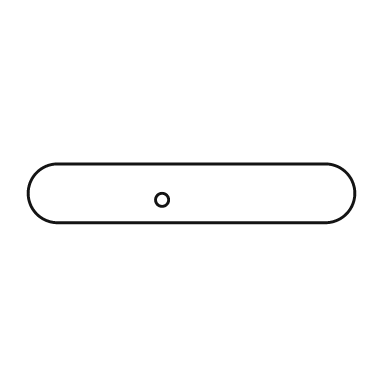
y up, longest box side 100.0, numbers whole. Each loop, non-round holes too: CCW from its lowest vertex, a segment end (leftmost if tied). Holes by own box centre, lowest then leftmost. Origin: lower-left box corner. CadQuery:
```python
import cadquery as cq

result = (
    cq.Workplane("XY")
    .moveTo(9.0, 0.0)
    .lineTo(91.0, 0.0)
    .threePointArc((100.0, 9.0), (91.0, 18.0))
    .lineTo(9.0, 18.0)
    .threePointArc((0.0, 9.0), (9.0, 0.0))
    .close()
    .moveTo(41.0, 7.0)
    .circle(2.0)
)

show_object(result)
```